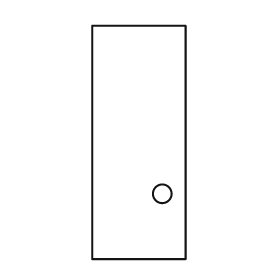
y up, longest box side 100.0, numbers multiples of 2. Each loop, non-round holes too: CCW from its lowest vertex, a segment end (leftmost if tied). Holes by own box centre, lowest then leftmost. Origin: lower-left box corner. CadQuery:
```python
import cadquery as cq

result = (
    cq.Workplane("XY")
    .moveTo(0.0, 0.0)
    .lineTo(40.0, 0.0)
    .lineTo(40.0, 100.0)
    .lineTo(0.0, 100.0)
    .close()
    .moveTo(30.0, 28.0)
    .circle(4.0)
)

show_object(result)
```